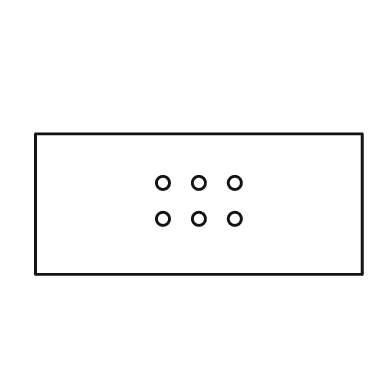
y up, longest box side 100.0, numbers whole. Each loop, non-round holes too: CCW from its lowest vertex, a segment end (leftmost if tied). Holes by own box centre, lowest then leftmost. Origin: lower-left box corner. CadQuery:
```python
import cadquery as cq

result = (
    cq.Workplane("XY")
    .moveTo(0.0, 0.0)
    .lineTo(100.0, 0.0)
    .lineTo(100.0, 43.0)
    .lineTo(0.0, 43.0)
    .close()
    .moveTo(39.0, 17.0)
    .circle(2.0)
    .moveTo(50.0, 17.0)
    .circle(2.0)
    .moveTo(61.0, 17.0)
    .circle(2.0)
    .moveTo(39.0, 28.0)
    .circle(2.0)
    .moveTo(50.0, 28.0)
    .circle(2.0)
    .moveTo(61.0, 28.0)
    .circle(2.0)
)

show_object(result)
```